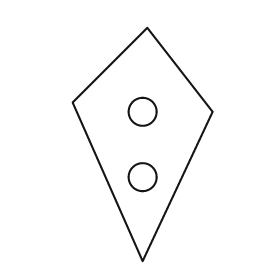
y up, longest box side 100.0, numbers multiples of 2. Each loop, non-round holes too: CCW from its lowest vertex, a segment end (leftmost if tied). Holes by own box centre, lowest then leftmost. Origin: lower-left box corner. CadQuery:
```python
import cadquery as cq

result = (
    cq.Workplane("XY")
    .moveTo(30.0, 0.0)
    .lineTo(60.0, 64.0)
    .lineTo(32.0, 100.0)
    .lineTo(0.0, 68.0)
    .close()
    .moveTo(30.0, 36.0)
    .circle(6.0)
    .moveTo(30.0, 64.0)
    .circle(6.0)
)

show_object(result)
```